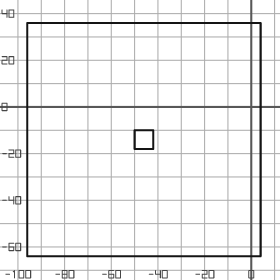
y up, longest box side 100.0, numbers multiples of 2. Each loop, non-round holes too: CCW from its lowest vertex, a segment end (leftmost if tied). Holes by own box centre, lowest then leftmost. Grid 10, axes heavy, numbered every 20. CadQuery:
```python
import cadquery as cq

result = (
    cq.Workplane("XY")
    .moveTo(-96.0, -64.0)
    .lineTo(4.0, -64.0)
    .lineTo(4.0, 36.0)
    .lineTo(-96.0, 36.0)
    .close()
    .moveTo(-50.0, -18.0)
    .lineTo(-42.0, -18.0)
    .lineTo(-42.0, -10.0)
    .lineTo(-50.0, -10.0)
    .close()
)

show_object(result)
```